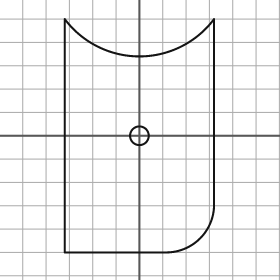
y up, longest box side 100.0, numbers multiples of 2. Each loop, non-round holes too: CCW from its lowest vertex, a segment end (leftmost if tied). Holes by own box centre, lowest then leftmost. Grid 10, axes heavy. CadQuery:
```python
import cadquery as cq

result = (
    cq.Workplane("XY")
    .moveTo(-32.0, -50.0)
    .lineTo(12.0, -50.0)
    .threePointArc((26.0, -44.0), (32.0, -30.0))
    .lineTo(32.0, 50.0)
    .threePointArc((0.0, 34.0), (-32.0, 50.0))
    .close()
    .moveTo(0.0, 0.0)
    .circle(4.0)
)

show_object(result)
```